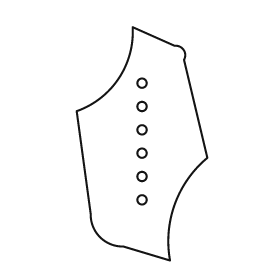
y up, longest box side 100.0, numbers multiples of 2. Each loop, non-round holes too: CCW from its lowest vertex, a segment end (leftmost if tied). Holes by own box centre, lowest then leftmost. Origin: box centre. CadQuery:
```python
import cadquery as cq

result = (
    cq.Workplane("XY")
    .moveTo(12.0, -50.0)
    .threePointArc((14.0, -26.0), (28.0, -6.0))
    .lineTo(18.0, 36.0)
    .threePointArc((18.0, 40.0), (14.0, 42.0))
    .lineTo(-4.0, 50.0)
    .threePointArc((-10.0, 28.0), (-28.0, 14.0))
    .lineTo(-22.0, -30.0)
    .threePointArc((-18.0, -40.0), (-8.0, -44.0))
    .close()
    .moveTo(0.0, -24.0)
    .circle(2.0)
    .moveTo(0.0, -14.0)
    .circle(2.0)
    .moveTo(0.0, -4.0)
    .circle(2.0)
    .moveTo(0.0, 6.0)
    .circle(2.0)
    .moveTo(0.0, 16.0)
    .circle(2.0)
    .moveTo(0.0, 26.0)
    .circle(2.0)
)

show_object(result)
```